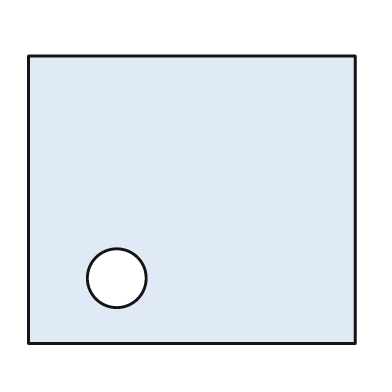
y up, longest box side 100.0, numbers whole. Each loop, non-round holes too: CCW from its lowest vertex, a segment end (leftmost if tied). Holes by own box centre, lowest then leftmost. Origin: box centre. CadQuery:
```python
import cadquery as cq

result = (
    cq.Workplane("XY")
    .moveTo(-50.0, -44.0)
    .lineTo(50.0, -44.0)
    .lineTo(50.0, 44.0)
    .lineTo(-50.0, 44.0)
    .close()
    .moveTo(-23.0, -24.0)
    .circle(9.0)
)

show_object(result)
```